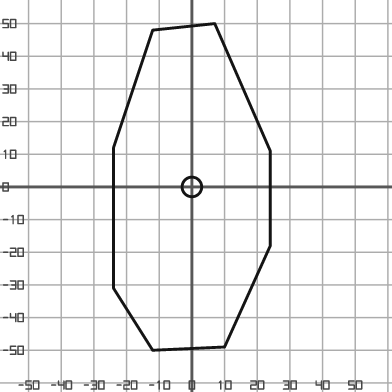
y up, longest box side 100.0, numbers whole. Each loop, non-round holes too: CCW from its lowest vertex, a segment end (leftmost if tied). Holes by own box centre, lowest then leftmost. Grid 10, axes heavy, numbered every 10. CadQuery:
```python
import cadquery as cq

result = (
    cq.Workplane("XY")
    .moveTo(-12.0, -50.0)
    .lineTo(10.0, -49.0)
    .lineTo(24.0, -18.0)
    .lineTo(24.0, 11.0)
    .lineTo(7.0, 50.0)
    .lineTo(-12.0, 48.0)
    .lineTo(-24.0, 12.0)
    .lineTo(-24.0, -31.0)
    .close()
    .moveTo(0.0, 0.0)
    .circle(3.0)
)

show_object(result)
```